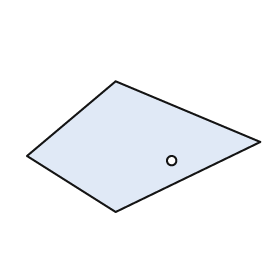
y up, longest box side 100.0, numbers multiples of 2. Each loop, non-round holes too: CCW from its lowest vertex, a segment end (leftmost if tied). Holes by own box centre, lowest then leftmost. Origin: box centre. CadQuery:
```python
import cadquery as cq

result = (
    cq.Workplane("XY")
    .moveTo(-12.0, -28.0)
    .lineTo(50.0, 2.0)
    .lineTo(-12.0, 28.0)
    .lineTo(-50.0, -4.0)
    .close()
    .moveTo(12.0, -6.0)
    .circle(2.0)
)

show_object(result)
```